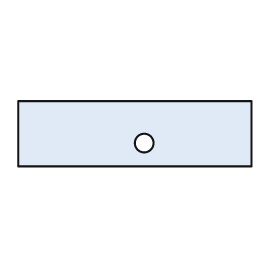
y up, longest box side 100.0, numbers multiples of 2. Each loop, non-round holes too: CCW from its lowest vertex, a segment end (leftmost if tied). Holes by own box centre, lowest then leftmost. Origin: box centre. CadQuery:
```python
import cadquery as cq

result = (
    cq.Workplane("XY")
    .moveTo(-50.0, -14.0)
    .lineTo(50.0, -14.0)
    .lineTo(50.0, 14.0)
    .lineTo(-50.0, 14.0)
    .close()
    .moveTo(4.0, -4.0)
    .circle(4.0)
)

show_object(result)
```